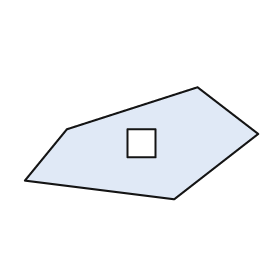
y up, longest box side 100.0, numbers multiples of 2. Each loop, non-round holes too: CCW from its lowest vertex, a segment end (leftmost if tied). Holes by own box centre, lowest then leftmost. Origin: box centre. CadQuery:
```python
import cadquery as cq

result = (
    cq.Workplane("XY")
    .moveTo(14.0, -24.0)
    .lineTo(50.0, 4.0)
    .lineTo(24.0, 24.0)
    .lineTo(-32.0, 6.0)
    .lineTo(-50.0, -16.0)
    .close()
    .moveTo(-6.0, -6.0)
    .lineTo(6.0, -6.0)
    .lineTo(6.0, 6.0)
    .lineTo(-6.0, 6.0)
    .close()
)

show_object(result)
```